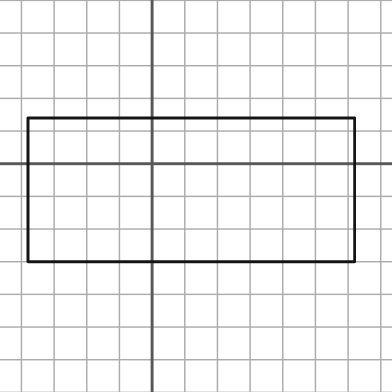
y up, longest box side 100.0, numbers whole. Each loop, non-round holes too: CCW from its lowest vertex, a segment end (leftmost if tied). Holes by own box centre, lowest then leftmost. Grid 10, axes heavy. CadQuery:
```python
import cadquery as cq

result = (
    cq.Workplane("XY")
    .moveTo(-38.0, -30.0)
    .lineTo(62.0, -30.0)
    .lineTo(62.0, 14.0)
    .lineTo(-38.0, 14.0)
    .close()
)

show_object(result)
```